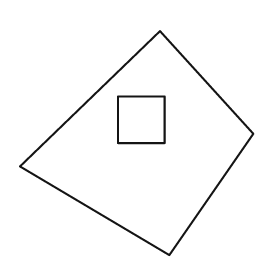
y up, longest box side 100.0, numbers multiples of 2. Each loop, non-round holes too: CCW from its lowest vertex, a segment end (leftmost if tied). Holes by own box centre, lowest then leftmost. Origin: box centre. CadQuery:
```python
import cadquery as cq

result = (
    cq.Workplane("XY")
    .moveTo(14.0, -48.0)
    .lineTo(50.0, 4.0)
    .lineTo(10.0, 48.0)
    .lineTo(-50.0, -10.0)
    .close()
    .moveTo(-8.0, 0.0)
    .lineTo(12.0, 0.0)
    .lineTo(12.0, 20.0)
    .lineTo(-8.0, 20.0)
    .close()
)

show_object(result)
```